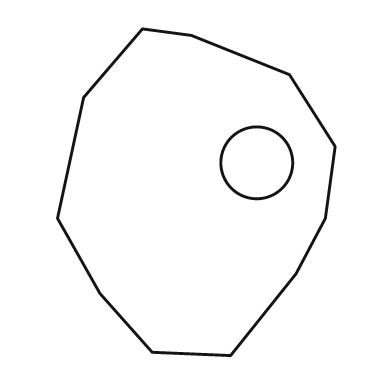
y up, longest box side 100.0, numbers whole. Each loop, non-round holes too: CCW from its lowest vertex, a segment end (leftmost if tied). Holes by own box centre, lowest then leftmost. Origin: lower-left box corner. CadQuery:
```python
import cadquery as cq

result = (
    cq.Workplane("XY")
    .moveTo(53.0, 0.0)
    .lineTo(73.0, 25.0)
    .lineTo(82.0, 42.0)
    .lineTo(85.0, 64.0)
    .lineTo(71.0, 86.0)
    .lineTo(41.0, 98.0)
    .lineTo(26.0, 100.0)
    .lineTo(8.0, 79.0)
    .lineTo(0.0, 42.0)
    .lineTo(13.0, 19.0)
    .lineTo(29.0, 1.0)
    .close()
    .moveTo(61.0, 59.0)
    .circle(11.0)
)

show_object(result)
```